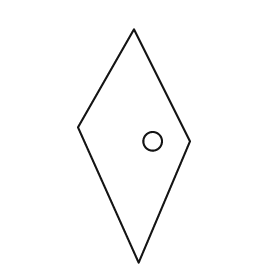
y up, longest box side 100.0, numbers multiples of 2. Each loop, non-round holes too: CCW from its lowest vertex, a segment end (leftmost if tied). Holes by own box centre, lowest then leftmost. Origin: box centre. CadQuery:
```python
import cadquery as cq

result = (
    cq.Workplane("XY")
    .moveTo(2.0, -50.0)
    .lineTo(24.0, 2.0)
    .lineTo(0.0, 50.0)
    .lineTo(-24.0, 8.0)
    .close()
    .moveTo(8.0, 2.0)
    .circle(4.0)
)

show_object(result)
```